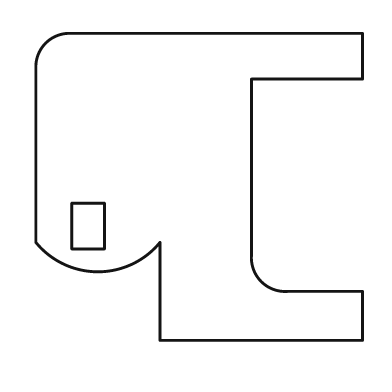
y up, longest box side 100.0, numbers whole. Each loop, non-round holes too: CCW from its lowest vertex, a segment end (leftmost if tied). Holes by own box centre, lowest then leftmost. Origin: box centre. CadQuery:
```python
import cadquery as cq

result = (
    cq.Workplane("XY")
    .moveTo(-12.0, -47.0)
    .lineTo(50.0, -47.0)
    .lineTo(50.0, -32.0)
    .lineTo(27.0, -32.0)
    .threePointArc((19.0, -29.0), (16.0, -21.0))
    .lineTo(16.0, 33.0)
    .lineTo(50.0, 33.0)
    .lineTo(50.0, 47.0)
    .lineTo(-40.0, 47.0)
    .threePointArc((-47.0, 44.0), (-50.0, 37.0))
    .lineTo(-50.0, -17.0)
    .threePointArc((-31.0, -26.0), (-12.0, -17.0))
    .close()
    .moveTo(-39.0, -19.0)
    .lineTo(-29.0, -19.0)
    .lineTo(-29.0, -5.0)
    .lineTo(-39.0, -5.0)
    .close()
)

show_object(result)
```